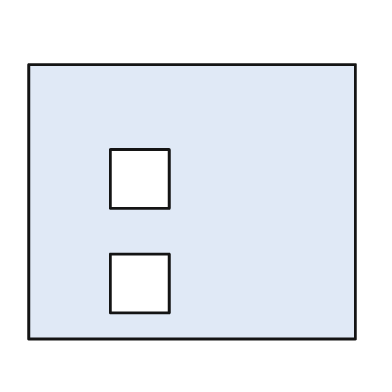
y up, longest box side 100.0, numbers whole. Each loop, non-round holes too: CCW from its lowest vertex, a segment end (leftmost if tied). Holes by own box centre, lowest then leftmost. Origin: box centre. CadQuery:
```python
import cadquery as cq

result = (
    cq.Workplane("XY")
    .moveTo(-50.0, -42.0)
    .lineTo(50.0, -42.0)
    .lineTo(50.0, 42.0)
    .lineTo(-50.0, 42.0)
    .close()
    .moveTo(-25.0, -34.0)
    .lineTo(-7.0, -34.0)
    .lineTo(-7.0, -16.0)
    .lineTo(-25.0, -16.0)
    .close()
    .moveTo(-25.0, -2.0)
    .lineTo(-7.0, -2.0)
    .lineTo(-7.0, 16.0)
    .lineTo(-25.0, 16.0)
    .close()
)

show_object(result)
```